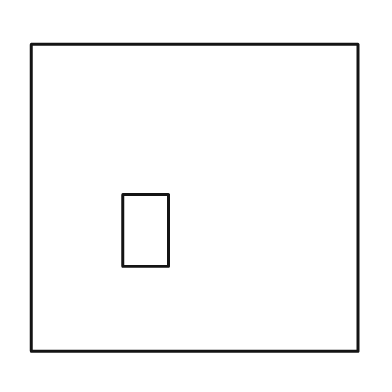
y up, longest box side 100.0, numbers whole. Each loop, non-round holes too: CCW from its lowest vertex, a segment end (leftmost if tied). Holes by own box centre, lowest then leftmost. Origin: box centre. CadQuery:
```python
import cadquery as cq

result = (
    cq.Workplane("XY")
    .moveTo(-50.0, -47.0)
    .lineTo(50.0, -47.0)
    .lineTo(50.0, 47.0)
    .lineTo(-50.0, 47.0)
    .close()
    .moveTo(-22.0, -21.0)
    .lineTo(-8.0, -21.0)
    .lineTo(-8.0, 1.0)
    .lineTo(-22.0, 1.0)
    .close()
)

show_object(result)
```